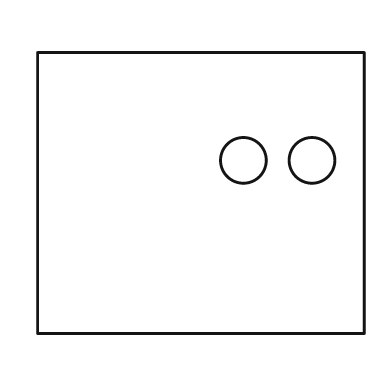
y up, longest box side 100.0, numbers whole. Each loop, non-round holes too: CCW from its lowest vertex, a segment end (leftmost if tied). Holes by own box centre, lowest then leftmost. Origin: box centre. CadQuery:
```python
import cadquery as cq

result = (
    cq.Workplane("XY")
    .moveTo(-50.0, -43.0)
    .lineTo(50.0, -43.0)
    .lineTo(50.0, 43.0)
    .lineTo(-50.0, 43.0)
    .close()
    .moveTo(13.0, 10.0)
    .circle(7.0)
    .moveTo(34.0, 10.0)
    .circle(7.0)
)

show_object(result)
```